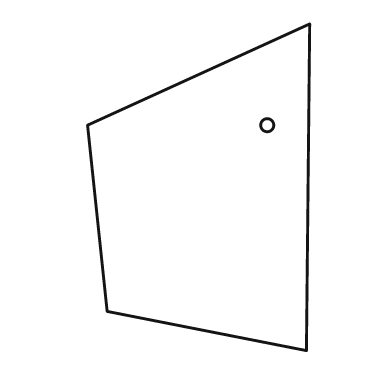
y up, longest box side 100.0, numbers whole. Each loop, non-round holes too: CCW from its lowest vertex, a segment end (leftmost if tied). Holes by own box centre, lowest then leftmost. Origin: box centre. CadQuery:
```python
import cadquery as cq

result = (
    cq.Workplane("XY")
    .moveTo(33.0, -50.0)
    .lineTo(34.0, 50.0)
    .lineTo(-34.0, 19.0)
    .lineTo(-28.0, -38.0)
    .close()
    .moveTo(21.0, 19.0)
    .circle(2.0)
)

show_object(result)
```